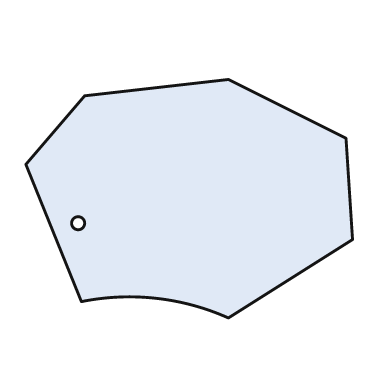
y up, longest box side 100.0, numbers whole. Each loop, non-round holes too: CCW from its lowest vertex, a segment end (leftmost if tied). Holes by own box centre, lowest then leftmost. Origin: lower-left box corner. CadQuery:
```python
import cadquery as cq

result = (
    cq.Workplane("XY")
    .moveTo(62.0, 0.0)
    .lineTo(100.0, 24.0)
    .lineTo(98.0, 55.0)
    .lineTo(62.0, 73.0)
    .lineTo(18.0, 68.0)
    .lineTo(0.0, 47.0)
    .lineTo(17.0, 5.0)
    .threePointArc((40.0, 6.0), (62.0, 0.0))
    .close()
    .moveTo(16.0, 29.0)
    .circle(2.0)
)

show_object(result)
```